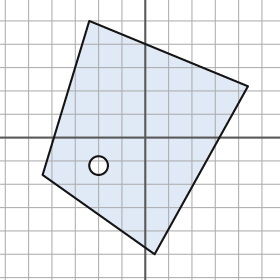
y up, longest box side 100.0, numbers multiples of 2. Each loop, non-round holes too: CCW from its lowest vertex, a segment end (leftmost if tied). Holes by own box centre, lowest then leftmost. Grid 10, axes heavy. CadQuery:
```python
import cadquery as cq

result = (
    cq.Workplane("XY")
    .moveTo(4.0, -50.0)
    .lineTo(44.0, 22.0)
    .lineTo(-24.0, 50.0)
    .lineTo(-44.0, -16.0)
    .close()
    .moveTo(-20.0, -12.0)
    .circle(4.0)
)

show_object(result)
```